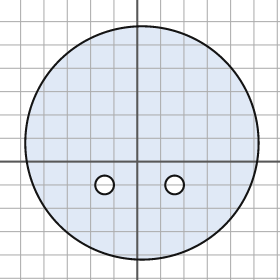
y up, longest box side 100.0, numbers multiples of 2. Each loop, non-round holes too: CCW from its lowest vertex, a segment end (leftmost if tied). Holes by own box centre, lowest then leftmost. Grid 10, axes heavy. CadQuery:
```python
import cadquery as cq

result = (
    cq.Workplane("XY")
    .moveTo(2.0, 8.0)
    .circle(50.0)
    .moveTo(-14.0, -10.0)
    .circle(4.0)
    .moveTo(16.0, -10.0)
    .circle(4.0)
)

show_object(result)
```